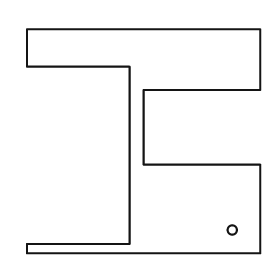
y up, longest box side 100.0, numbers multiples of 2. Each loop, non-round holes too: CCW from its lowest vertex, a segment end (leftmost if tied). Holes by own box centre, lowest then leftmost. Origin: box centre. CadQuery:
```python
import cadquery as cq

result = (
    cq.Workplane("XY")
    .moveTo(-50.0, -48.0)
    .lineTo(50.0, -48.0)
    .lineTo(50.0, -10.0)
    .lineTo(0.0, -10.0)
    .lineTo(0.0, 22.0)
    .lineTo(50.0, 22.0)
    .lineTo(50.0, 48.0)
    .lineTo(-50.0, 48.0)
    .lineTo(-50.0, 32.0)
    .lineTo(-6.0, 32.0)
    .lineTo(-6.0, -44.0)
    .lineTo(-50.0, -44.0)
    .close()
    .moveTo(38.0, -38.0)
    .circle(2.0)
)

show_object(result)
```